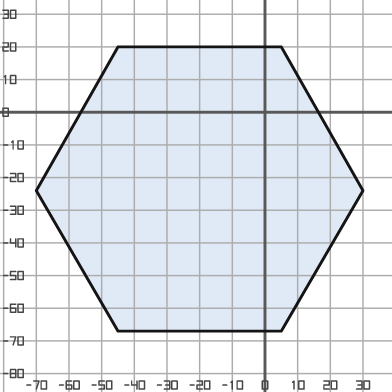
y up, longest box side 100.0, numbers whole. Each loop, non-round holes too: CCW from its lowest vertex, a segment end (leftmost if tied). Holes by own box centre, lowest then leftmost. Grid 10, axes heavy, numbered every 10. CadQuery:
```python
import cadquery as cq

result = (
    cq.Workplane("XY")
    .moveTo(-45.0, -67.0)
    .lineTo(5.0, -67.0)
    .lineTo(30.0, -24.0)
    .lineTo(5.0, 20.0)
    .lineTo(-45.0, 20.0)
    .lineTo(-70.0, -24.0)
    .close()
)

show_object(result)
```